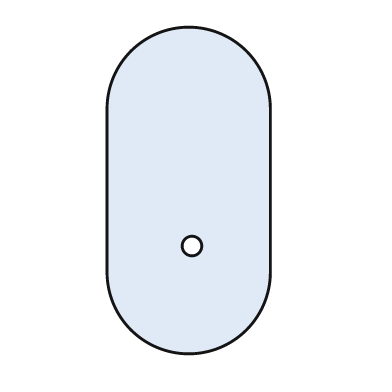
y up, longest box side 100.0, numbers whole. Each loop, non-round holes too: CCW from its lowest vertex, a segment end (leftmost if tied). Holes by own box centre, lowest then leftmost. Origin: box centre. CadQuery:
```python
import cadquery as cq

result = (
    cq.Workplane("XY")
    .moveTo(-25.0, -25.0)
    .threePointArc((0.0, -50.0), (25.0, -25.0))
    .lineTo(25.0, 25.0)
    .threePointArc((0.0, 50.0), (-25.0, 25.0))
    .close()
    .moveTo(1.0, -17.0)
    .circle(3.0)
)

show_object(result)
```